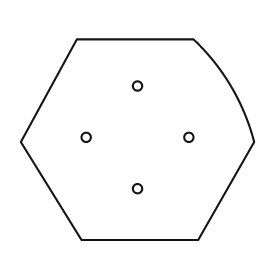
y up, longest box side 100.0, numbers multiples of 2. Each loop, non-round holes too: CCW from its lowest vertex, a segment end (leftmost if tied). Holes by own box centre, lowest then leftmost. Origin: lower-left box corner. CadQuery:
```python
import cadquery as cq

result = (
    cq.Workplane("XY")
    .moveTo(26.0, 0.0)
    .lineTo(76.0, 0.0)
    .lineTo(100.0, 42.0)
    .threePointArc((90.0, 66.0), (74.0, 86.0))
    .lineTo(24.0, 86.0)
    .lineTo(0.0, 42.0)
    .close()
    .moveTo(50.0, 22.0)
    .circle(2.0)
    .moveTo(28.0, 44.0)
    .circle(2.0)
    .moveTo(72.0, 44.0)
    .circle(2.0)
    .moveTo(50.0, 66.0)
    .circle(2.0)
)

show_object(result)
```